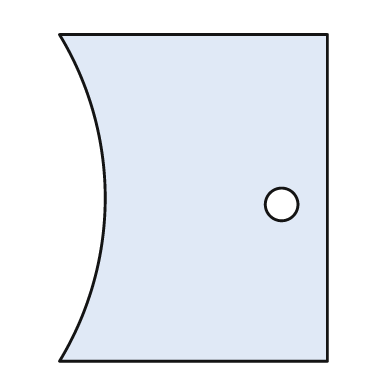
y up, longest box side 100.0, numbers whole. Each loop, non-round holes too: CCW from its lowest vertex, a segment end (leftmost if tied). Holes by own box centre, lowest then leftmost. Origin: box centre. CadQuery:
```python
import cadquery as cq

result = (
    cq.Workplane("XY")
    .moveTo(-41.0, -50.0)
    .lineTo(41.0, -50.0)
    .lineTo(41.0, 50.0)
    .lineTo(-41.0, 50.0)
    .threePointArc((-27.0, 0.0), (-41.0, -50.0))
    .close()
    .moveTo(27.0, -2.0)
    .circle(5.0)
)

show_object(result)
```